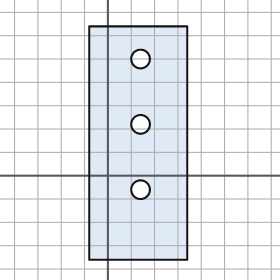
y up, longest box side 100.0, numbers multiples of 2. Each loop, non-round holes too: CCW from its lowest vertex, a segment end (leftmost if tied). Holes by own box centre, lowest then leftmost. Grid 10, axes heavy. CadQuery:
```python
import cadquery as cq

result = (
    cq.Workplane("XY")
    .moveTo(-8.0, -36.0)
    .lineTo(34.0, -36.0)
    .lineTo(34.0, 64.0)
    .lineTo(-8.0, 64.0)
    .close()
    .moveTo(14.0, -6.0)
    .circle(4.0)
    .moveTo(14.0, 22.0)
    .circle(4.0)
    .moveTo(14.0, 50.0)
    .circle(4.0)
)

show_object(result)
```